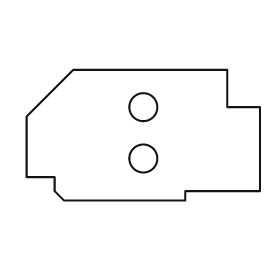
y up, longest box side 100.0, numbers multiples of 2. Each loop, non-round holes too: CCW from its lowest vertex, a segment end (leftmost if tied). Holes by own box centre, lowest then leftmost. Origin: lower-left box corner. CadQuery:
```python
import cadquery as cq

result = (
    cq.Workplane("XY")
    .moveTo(16.0, 0.0)
    .lineTo(68.0, 0.0)
    .lineTo(68.0, 4.0)
    .lineTo(100.0, 4.0)
    .lineTo(100.0, 40.0)
    .lineTo(86.0, 40.0)
    .lineTo(86.0, 56.0)
    .lineTo(20.0, 56.0)
    .lineTo(0.0, 36.0)
    .lineTo(0.0, 10.0)
    .lineTo(12.0, 10.0)
    .lineTo(12.0, 4.0)
    .close()
    .moveTo(50.0, 18.0)
    .circle(6.0)
    .moveTo(50.0, 40.0)
    .circle(6.0)
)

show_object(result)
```